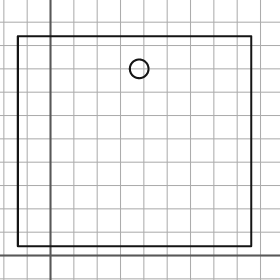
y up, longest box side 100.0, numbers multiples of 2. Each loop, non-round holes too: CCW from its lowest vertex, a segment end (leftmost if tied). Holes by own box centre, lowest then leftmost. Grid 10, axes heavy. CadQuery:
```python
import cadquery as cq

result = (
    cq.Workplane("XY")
    .moveTo(-14.0, 4.0)
    .lineTo(86.0, 4.0)
    .lineTo(86.0, 94.0)
    .lineTo(-14.0, 94.0)
    .close()
    .moveTo(38.0, 80.0)
    .circle(4.0)
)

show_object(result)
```